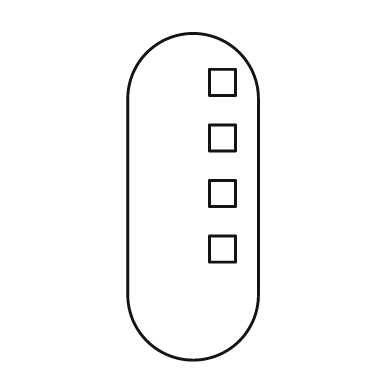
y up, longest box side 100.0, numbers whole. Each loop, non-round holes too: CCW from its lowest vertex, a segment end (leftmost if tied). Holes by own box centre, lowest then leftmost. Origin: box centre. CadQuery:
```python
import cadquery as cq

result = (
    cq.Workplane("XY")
    .moveTo(-20.0, -30.0)
    .threePointArc((0.0, -50.0), (20.0, -30.0))
    .lineTo(20.0, 30.0)
    .threePointArc((0.0, 50.0), (-20.0, 30.0))
    .close()
    .moveTo(5.0, -20.0)
    .lineTo(13.0, -20.0)
    .lineTo(13.0, -12.0)
    .lineTo(5.0, -12.0)
    .close()
    .moveTo(5.0, -3.0)
    .lineTo(13.0, -3.0)
    .lineTo(13.0, 5.0)
    .lineTo(5.0, 5.0)
    .close()
    .moveTo(5.0, 14.0)
    .lineTo(13.0, 14.0)
    .lineTo(13.0, 22.0)
    .lineTo(5.0, 22.0)
    .close()
    .moveTo(5.0, 31.0)
    .lineTo(13.0, 31.0)
    .lineTo(13.0, 39.0)
    .lineTo(5.0, 39.0)
    .close()
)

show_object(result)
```